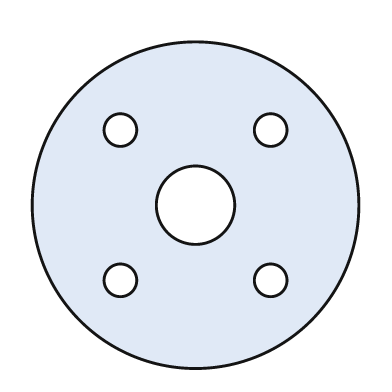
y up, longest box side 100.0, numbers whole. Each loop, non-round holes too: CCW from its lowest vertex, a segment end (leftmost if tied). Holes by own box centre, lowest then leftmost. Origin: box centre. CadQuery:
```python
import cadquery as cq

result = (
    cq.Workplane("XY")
    .moveTo(0.0, 0.0)
    .circle(50.0)
    .moveTo(-23.0, -23.0)
    .circle(5.0)
    .moveTo(23.0, -23.0)
    .circle(5.0)
    .moveTo(0.0, 0.0)
    .circle(12.0)
    .moveTo(-23.0, 23.0)
    .circle(5.0)
    .moveTo(23.0, 23.0)
    .circle(5.0)
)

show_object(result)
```